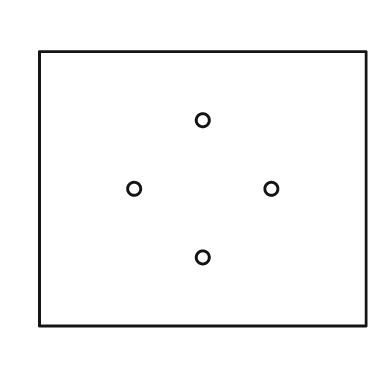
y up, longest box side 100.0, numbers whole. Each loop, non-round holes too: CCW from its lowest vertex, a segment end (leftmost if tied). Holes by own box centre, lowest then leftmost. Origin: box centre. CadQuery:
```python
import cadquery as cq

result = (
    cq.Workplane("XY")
    .moveTo(-50.0, -42.0)
    .lineTo(50.0, -42.0)
    .lineTo(50.0, 42.0)
    .lineTo(-50.0, 42.0)
    .close()
    .moveTo(0.0, -21.0)
    .circle(2.0)
    .moveTo(-21.0, 0.0)
    .circle(2.0)
    .moveTo(21.0, 0.0)
    .circle(2.0)
    .moveTo(0.0, 21.0)
    .circle(2.0)
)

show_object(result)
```